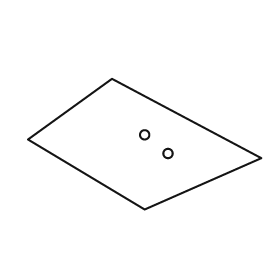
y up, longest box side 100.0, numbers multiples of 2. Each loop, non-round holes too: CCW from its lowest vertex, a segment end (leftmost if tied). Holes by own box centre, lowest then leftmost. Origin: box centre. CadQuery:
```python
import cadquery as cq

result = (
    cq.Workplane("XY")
    .moveTo(0.0, -28.0)
    .lineTo(50.0, -6.0)
    .lineTo(-14.0, 28.0)
    .lineTo(-50.0, 2.0)
    .close()
    .moveTo(10.0, -4.0)
    .circle(2.0)
    .moveTo(0.0, 4.0)
    .circle(2.0)
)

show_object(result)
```